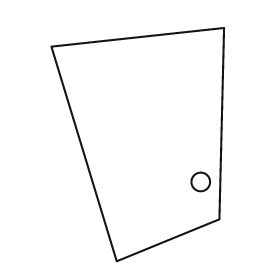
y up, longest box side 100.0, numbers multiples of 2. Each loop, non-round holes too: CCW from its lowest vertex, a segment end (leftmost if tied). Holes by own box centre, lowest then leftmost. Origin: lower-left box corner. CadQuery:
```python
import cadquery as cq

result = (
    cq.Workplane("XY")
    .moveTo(28.0, 0.0)
    .lineTo(72.0, 18.0)
    .lineTo(74.0, 100.0)
    .lineTo(0.0, 92.0)
    .close()
    .moveTo(64.0, 34.0)
    .circle(4.0)
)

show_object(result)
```